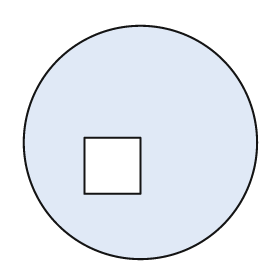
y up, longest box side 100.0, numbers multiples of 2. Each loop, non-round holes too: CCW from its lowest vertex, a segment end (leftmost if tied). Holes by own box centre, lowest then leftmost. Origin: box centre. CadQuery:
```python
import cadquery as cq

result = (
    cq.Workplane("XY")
    .moveTo(0.0, 0.0)
    .circle(50.0)
    .moveTo(-24.0, -22.0)
    .lineTo(0.0, -22.0)
    .lineTo(0.0, 2.0)
    .lineTo(-24.0, 2.0)
    .close()
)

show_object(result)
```